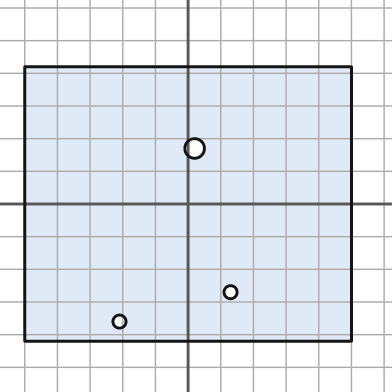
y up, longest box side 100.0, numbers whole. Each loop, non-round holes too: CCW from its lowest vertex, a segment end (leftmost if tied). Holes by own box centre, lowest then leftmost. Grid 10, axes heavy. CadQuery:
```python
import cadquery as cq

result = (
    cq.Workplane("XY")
    .moveTo(-50.0, -42.0)
    .lineTo(50.0, -42.0)
    .lineTo(50.0, 42.0)
    .lineTo(-50.0, 42.0)
    .close()
    .moveTo(-21.0, -36.0)
    .circle(2.0)
    .moveTo(13.0, -27.0)
    .circle(2.0)
    .moveTo(2.0, 17.0)
    .circle(3.0)
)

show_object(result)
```